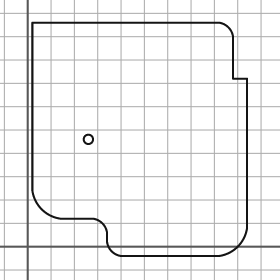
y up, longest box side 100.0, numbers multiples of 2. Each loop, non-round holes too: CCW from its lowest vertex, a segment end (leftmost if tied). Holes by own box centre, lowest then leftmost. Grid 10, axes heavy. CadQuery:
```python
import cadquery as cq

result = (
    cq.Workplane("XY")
    .moveTo(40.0, -4.0)
    .lineTo(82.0, -4.0)
    .threePointArc((90.0, 0.0), (94.0, 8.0))
    .lineTo(94.0, 72.0)
    .lineTo(88.0, 72.0)
    .lineTo(88.0, 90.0)
    .threePointArc((86.0, 94.0), (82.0, 96.0))
    .lineTo(2.0, 96.0)
    .lineTo(2.0, 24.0)
    .threePointArc((6.0, 16.0), (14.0, 12.0))
    .lineTo(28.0, 12.0)
    .threePointArc((32.0, 10.0), (34.0, 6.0))
    .lineTo(34.0, 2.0)
    .threePointArc((36.0, -2.0), (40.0, -4.0))
    .close()
    .moveTo(26.0, 46.0)
    .circle(2.0)
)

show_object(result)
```